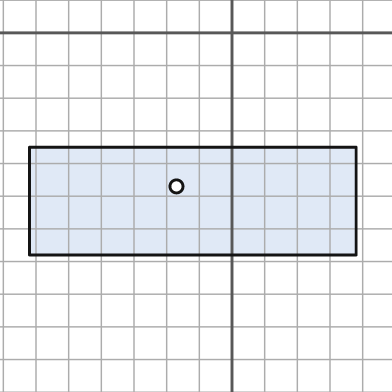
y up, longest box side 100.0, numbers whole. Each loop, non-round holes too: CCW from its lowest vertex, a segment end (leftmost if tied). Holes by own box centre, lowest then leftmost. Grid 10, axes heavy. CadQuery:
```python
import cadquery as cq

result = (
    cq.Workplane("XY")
    .moveTo(-62.0, -68.0)
    .lineTo(38.0, -68.0)
    .lineTo(38.0, -35.0)
    .lineTo(-62.0, -35.0)
    .close()
    .moveTo(-17.0, -47.0)
    .circle(2.0)
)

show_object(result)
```